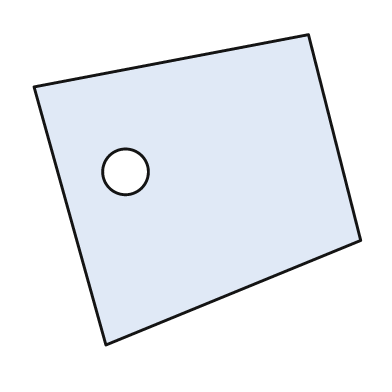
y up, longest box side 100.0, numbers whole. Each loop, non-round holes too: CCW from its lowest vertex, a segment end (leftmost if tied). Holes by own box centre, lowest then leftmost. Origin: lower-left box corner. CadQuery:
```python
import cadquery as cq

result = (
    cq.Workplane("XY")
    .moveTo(22.0, 0.0)
    .lineTo(100.0, 32.0)
    .lineTo(84.0, 95.0)
    .lineTo(0.0, 79.0)
    .close()
    .moveTo(28.0, 53.0)
    .circle(7.0)
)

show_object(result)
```